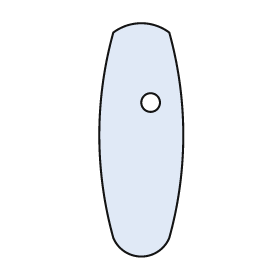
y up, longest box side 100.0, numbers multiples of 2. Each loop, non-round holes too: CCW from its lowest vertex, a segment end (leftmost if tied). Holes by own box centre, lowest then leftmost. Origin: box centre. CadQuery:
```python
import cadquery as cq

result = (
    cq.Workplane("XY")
    .moveTo(-12.0, -42.0)
    .threePointArc((0.0, -50.0), (12.0, -42.0))
    .threePointArc((18.0, 2.0), (12.0, 46.0))
    .threePointArc((0.0, 50.0), (-12.0, 46.0))
    .threePointArc((-18.0, 2.0), (-12.0, -42.0))
    .close()
    .moveTo(4.0, 16.0)
    .circle(4.0)
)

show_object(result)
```